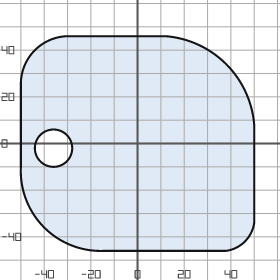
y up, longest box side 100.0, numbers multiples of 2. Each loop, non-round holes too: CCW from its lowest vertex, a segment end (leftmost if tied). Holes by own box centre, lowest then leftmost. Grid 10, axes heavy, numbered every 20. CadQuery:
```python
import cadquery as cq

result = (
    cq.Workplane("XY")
    .moveTo(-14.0, -46.0)
    .lineTo(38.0, -46.0)
    .threePointArc((46.0, -42.0), (50.0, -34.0))
    .lineTo(50.0, 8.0)
    .threePointArc((38.0, 34.0), (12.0, 46.0))
    .lineTo(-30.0, 46.0)
    .threePointArc((-44.0, 40.0), (-50.0, 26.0))
    .lineTo(-50.0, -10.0)
    .threePointArc((-40.0, -36.0), (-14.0, -46.0))
    .close()
    .moveTo(-36.0, -2.0)
    .circle(8.0)
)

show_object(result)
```